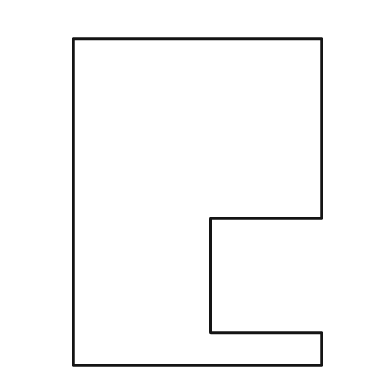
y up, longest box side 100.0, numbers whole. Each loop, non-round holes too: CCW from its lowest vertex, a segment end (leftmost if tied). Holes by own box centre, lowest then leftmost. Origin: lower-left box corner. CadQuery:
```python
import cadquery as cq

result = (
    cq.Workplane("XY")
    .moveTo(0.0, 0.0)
    .lineTo(76.0, 0.0)
    .lineTo(76.0, 10.0)
    .lineTo(42.0, 10.0)
    .lineTo(42.0, 45.0)
    .lineTo(76.0, 45.0)
    .lineTo(76.0, 100.0)
    .lineTo(0.0, 100.0)
    .close()
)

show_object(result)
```